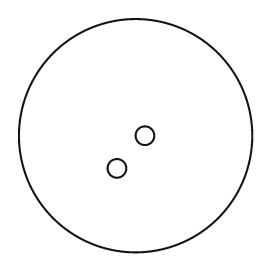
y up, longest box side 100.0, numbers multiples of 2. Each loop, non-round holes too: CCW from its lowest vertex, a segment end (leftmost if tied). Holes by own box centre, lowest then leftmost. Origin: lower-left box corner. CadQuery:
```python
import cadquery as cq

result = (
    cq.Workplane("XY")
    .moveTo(50.0, 50.0)
    .circle(50.0)
    .moveTo(42.0, 36.0)
    .circle(4.0)
    .moveTo(54.0, 50.0)
    .circle(4.0)
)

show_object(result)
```